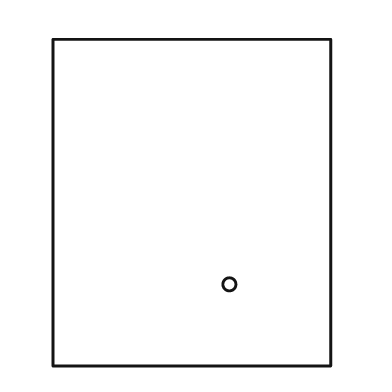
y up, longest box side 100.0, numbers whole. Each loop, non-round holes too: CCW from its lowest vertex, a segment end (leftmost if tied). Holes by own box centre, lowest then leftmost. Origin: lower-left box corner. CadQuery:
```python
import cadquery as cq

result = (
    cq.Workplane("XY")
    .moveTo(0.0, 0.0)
    .lineTo(85.0, 0.0)
    .lineTo(85.0, 100.0)
    .lineTo(0.0, 100.0)
    .close()
    .moveTo(54.0, 25.0)
    .circle(2.0)
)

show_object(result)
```